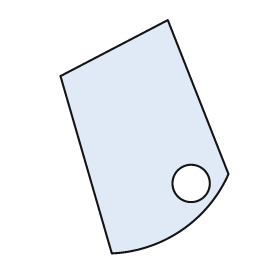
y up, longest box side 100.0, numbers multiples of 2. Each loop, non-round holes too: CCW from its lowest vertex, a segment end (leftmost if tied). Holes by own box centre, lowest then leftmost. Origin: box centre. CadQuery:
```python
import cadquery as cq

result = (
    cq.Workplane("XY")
    .moveTo(-14.0, -50.0)
    .threePointArc((16.0, -40.0), (36.0, -16.0))
    .lineTo(10.0, 50.0)
    .lineTo(-36.0, 26.0)
    .close()
    .moveTo(20.0, -20.0)
    .circle(8.0)
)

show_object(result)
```